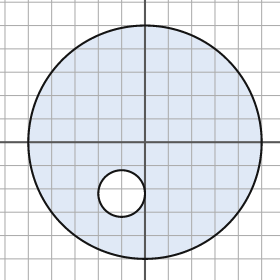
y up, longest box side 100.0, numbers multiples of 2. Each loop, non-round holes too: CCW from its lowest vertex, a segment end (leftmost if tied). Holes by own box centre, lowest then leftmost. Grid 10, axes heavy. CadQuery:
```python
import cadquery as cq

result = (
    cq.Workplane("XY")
    .moveTo(0.0, 0.0)
    .circle(50.0)
    .moveTo(-10.0, -22.0)
    .circle(10.0)
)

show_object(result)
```